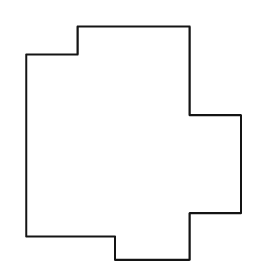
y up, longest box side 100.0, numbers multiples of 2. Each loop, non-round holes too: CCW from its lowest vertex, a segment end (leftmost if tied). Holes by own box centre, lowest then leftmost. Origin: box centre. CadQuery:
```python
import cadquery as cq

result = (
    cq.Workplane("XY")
    .moveTo(-8.0, -50.0)
    .lineTo(24.0, -50.0)
    .lineTo(24.0, -30.0)
    .lineTo(46.0, -30.0)
    .lineTo(46.0, 12.0)
    .lineTo(24.0, 12.0)
    .lineTo(24.0, 50.0)
    .lineTo(-24.0, 50.0)
    .lineTo(-24.0, 38.0)
    .lineTo(-46.0, 38.0)
    .lineTo(-46.0, -40.0)
    .lineTo(-8.0, -40.0)
    .close()
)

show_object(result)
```